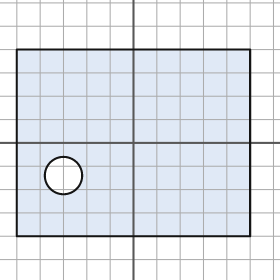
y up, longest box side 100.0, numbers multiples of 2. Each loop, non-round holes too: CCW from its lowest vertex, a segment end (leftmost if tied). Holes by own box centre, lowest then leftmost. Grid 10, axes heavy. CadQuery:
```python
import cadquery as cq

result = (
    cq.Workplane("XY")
    .moveTo(-50.0, -40.0)
    .lineTo(50.0, -40.0)
    .lineTo(50.0, 40.0)
    .lineTo(-50.0, 40.0)
    .close()
    .moveTo(-30.0, -14.0)
    .circle(8.0)
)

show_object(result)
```